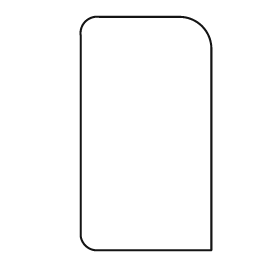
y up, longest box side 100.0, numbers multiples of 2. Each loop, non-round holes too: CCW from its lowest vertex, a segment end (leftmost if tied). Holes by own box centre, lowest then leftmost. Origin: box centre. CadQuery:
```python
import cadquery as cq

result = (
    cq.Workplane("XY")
    .moveTo(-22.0, -50.0)
    .lineTo(28.0, -50.0)
    .lineTo(28.0, 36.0)
    .threePointArc((24.0, 46.0), (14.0, 50.0))
    .lineTo(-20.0, 50.0)
    .threePointArc((-26.0, 48.0), (-28.0, 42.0))
    .lineTo(-28.0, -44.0)
    .threePointArc((-26.0, -48.0), (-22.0, -50.0))
    .close()
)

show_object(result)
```